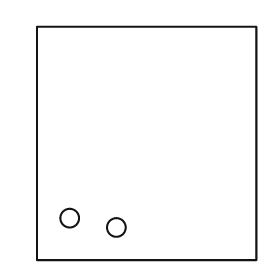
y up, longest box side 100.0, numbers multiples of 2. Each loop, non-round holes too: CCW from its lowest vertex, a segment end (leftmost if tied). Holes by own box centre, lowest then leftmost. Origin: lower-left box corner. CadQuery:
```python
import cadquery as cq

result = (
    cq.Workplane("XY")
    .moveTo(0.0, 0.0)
    .lineTo(94.0, 0.0)
    .lineTo(94.0, 100.0)
    .lineTo(0.0, 100.0)
    .close()
    .moveTo(34.0, 14.0)
    .circle(4.0)
    .moveTo(14.0, 18.0)
    .circle(4.0)
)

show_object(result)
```